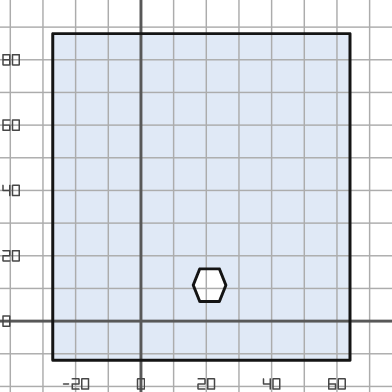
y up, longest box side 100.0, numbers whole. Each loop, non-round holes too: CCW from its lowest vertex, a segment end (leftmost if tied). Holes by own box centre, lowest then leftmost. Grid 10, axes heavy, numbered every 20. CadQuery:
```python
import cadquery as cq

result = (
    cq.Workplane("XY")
    .moveTo(-27.0, -12.0)
    .lineTo(64.0, -12.0)
    .lineTo(64.0, 88.0)
    .lineTo(-27.0, 88.0)
    .close()
    .moveTo(18.0, 6.0)
    .lineTo(24.0, 6.0)
    .lineTo(26.0, 11.0)
    .lineTo(24.0, 16.0)
    .lineTo(18.0, 16.0)
    .lineTo(16.0, 11.0)
    .close()
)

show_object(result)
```